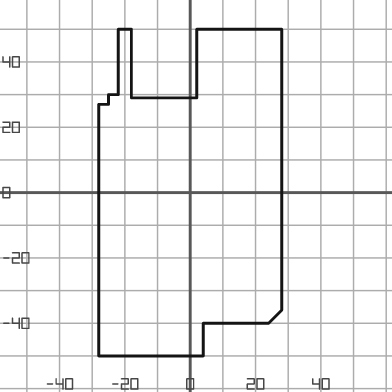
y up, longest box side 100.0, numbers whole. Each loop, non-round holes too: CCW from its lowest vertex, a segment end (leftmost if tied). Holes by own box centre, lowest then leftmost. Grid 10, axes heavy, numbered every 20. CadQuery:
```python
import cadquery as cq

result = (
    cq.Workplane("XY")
    .moveTo(-28.0, -50.0)
    .lineTo(4.0, -50.0)
    .lineTo(4.0, -40.0)
    .lineTo(24.0, -40.0)
    .lineTo(28.0, -36.0)
    .lineTo(28.0, 50.0)
    .lineTo(2.0, 50.0)
    .lineTo(2.0, 29.0)
    .lineTo(-18.0, 29.0)
    .lineTo(-18.0, 50.0)
    .lineTo(-22.0, 50.0)
    .lineTo(-22.0, 30.0)
    .lineTo(-25.0, 30.0)
    .lineTo(-25.0, 27.0)
    .lineTo(-28.0, 27.0)
    .close()
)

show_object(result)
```